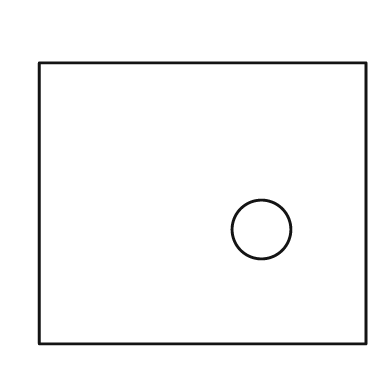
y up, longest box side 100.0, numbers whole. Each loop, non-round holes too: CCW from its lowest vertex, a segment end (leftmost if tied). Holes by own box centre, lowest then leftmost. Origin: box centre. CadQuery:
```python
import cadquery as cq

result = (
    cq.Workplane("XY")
    .moveTo(-50.0, -43.0)
    .lineTo(50.0, -43.0)
    .lineTo(50.0, 43.0)
    .lineTo(-50.0, 43.0)
    .close()
    .moveTo(18.0, -8.0)
    .circle(9.0)
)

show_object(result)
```